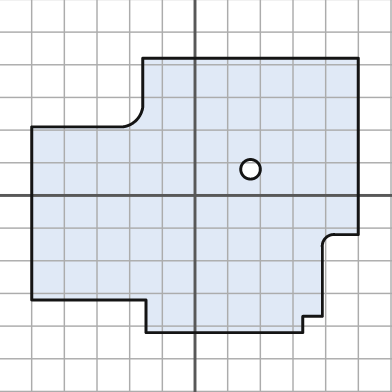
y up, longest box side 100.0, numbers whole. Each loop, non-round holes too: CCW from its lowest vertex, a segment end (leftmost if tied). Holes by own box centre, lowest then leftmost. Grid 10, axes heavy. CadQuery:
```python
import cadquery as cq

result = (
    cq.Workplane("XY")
    .moveTo(-15.0, -42.0)
    .lineTo(33.0, -42.0)
    .lineTo(33.0, -37.0)
    .lineTo(39.0, -37.0)
    .lineTo(39.0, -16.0)
    .threePointArc((40.0, -13.0), (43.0, -12.0))
    .lineTo(50.0, -12.0)
    .lineTo(50.0, 42.0)
    .lineTo(-16.0, 42.0)
    .lineTo(-16.0, 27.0)
    .threePointArc((-18.0, 23.0), (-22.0, 21.0))
    .lineTo(-50.0, 21.0)
    .lineTo(-50.0, -32.0)
    .lineTo(-15.0, -32.0)
    .close()
    .moveTo(17.0, 8.0)
    .circle(3.0)
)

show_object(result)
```